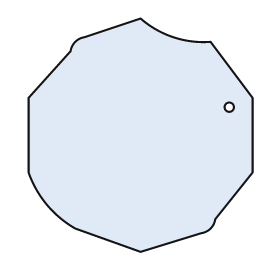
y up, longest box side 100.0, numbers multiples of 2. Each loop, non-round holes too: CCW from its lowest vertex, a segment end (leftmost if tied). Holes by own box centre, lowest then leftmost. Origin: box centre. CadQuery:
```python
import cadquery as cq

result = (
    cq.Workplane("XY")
    .moveTo(0.0, -50.0)
    .lineTo(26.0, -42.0)
    .threePointArc((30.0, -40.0), (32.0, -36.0))
    .lineTo(48.0, -16.0)
    .lineTo(48.0, 16.0)
    .lineTo(30.0, 40.0)
    .threePointArc((14.0, 42.0), (0.0, 50.0))
    .lineTo(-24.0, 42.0)
    .threePointArc((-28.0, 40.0), (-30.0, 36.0))
    .lineTo(-48.0, 16.0)
    .lineTo(-48.0, -16.0)
    .threePointArc((-40.0, -30.0), (-28.0, -40.0))
    .close()
    .moveTo(38.0, 12.0)
    .circle(2.0)
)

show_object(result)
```